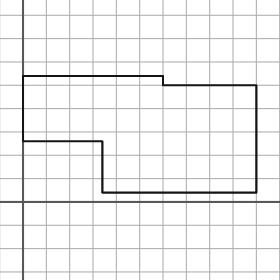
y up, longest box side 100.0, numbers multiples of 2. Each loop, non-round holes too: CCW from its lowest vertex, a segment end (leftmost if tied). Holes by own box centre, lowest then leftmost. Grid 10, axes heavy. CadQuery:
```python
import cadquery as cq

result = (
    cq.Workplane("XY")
    .moveTo(34.0, 4.0)
    .lineTo(100.0, 4.0)
    .lineTo(100.0, 50.0)
    .lineTo(60.0, 50.0)
    .lineTo(60.0, 54.0)
    .lineTo(0.0, 54.0)
    .lineTo(0.0, 26.0)
    .lineTo(34.0, 26.0)
    .close()
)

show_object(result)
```